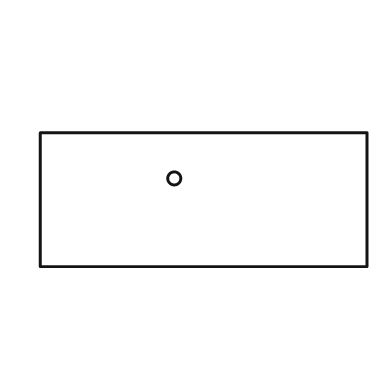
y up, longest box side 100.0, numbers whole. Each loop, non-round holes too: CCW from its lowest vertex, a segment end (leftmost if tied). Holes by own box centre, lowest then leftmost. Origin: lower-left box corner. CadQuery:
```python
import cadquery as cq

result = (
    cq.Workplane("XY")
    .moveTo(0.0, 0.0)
    .lineTo(100.0, 0.0)
    .lineTo(100.0, 41.0)
    .lineTo(0.0, 41.0)
    .close()
    .moveTo(41.0, 27.0)
    .circle(2.0)
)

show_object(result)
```